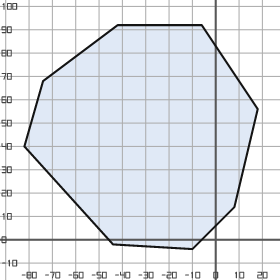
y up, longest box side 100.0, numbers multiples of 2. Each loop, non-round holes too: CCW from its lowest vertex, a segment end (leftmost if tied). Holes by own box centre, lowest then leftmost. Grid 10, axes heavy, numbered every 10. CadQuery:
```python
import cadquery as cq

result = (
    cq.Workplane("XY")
    .moveTo(-10.0, -4.0)
    .lineTo(8.0, 14.0)
    .lineTo(18.0, 56.0)
    .lineTo(-6.0, 92.0)
    .lineTo(-42.0, 92.0)
    .lineTo(-74.0, 68.0)
    .lineTo(-82.0, 40.0)
    .lineTo(-44.0, -2.0)
    .close()
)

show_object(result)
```